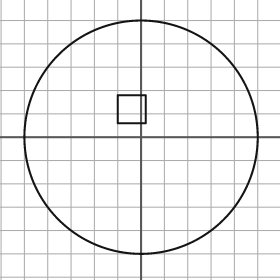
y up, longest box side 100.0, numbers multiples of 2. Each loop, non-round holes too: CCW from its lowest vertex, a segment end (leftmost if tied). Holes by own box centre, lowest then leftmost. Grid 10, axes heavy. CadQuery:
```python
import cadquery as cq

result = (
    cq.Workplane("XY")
    .moveTo(0.0, 0.0)
    .circle(50.0)
    .moveTo(-10.0, 6.0)
    .lineTo(2.0, 6.0)
    .lineTo(2.0, 18.0)
    .lineTo(-10.0, 18.0)
    .close()
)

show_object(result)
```